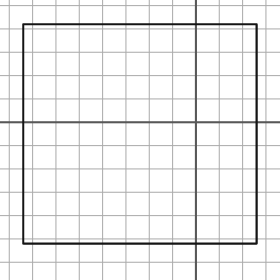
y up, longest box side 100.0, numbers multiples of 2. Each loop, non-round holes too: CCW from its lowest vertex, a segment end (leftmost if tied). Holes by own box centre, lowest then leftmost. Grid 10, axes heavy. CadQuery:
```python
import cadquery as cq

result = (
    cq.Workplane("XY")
    .moveTo(-74.0, -52.0)
    .lineTo(26.0, -52.0)
    .lineTo(26.0, 42.0)
    .lineTo(-74.0, 42.0)
    .close()
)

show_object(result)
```